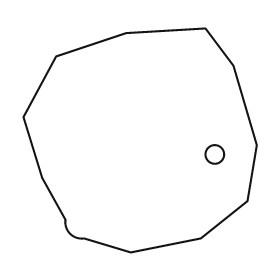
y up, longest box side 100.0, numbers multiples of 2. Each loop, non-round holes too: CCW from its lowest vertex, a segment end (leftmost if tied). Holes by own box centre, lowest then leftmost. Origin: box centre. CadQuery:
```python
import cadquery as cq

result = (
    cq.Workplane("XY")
    .moveTo(-4.0, -48.0)
    .lineTo(26.0, -42.0)
    .lineTo(46.0, -26.0)
    .lineTo(50.0, -2.0)
    .lineTo(40.0, 32.0)
    .lineTo(28.0, 48.0)
    .lineTo(-6.0, 46.0)
    .lineTo(-36.0, 36.0)
    .lineTo(-50.0, 10.0)
    .lineTo(-42.0, -16.0)
    .lineTo(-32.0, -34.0)
    .threePointArc((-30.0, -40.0), (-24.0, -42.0))
    .close()
    .moveTo(32.0, -6.0)
    .circle(4.0)
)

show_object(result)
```